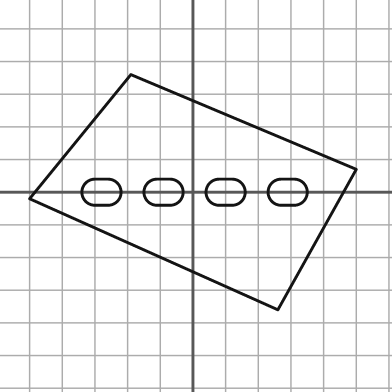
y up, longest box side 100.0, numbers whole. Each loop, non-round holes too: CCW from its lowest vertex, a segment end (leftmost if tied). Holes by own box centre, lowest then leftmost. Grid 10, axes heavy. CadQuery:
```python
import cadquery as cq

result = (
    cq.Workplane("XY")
    .moveTo(26.0, -36.0)
    .lineTo(50.0, 7.0)
    .lineTo(-19.0, 36.0)
    .lineTo(-50.0, -2.0)
    .close()
    .moveTo(-30.0, -4.0)
    .lineTo(-26.0, -4.0)
    .threePointArc((-22.0, 0.0), (-26.0, 4.0))
    .lineTo(-30.0, 4.0)
    .threePointArc((-34.0, 0.0), (-30.0, -4.0))
    .close()
    .moveTo(-11.0, -4.0)
    .lineTo(-7.0, -4.0)
    .threePointArc((-3.0, 0.0), (-7.0, 4.0))
    .lineTo(-11.0, 4.0)
    .threePointArc((-15.0, 0.0), (-11.0, -4.0))
    .close()
    .moveTo(8.0, -4.0)
    .lineTo(12.0, -4.0)
    .threePointArc((16.0, 0.0), (12.0, 4.0))
    .lineTo(8.0, 4.0)
    .threePointArc((4.0, 0.0), (8.0, -4.0))
    .close()
    .moveTo(27.0, -4.0)
    .lineTo(31.0, -4.0)
    .threePointArc((35.0, 0.0), (31.0, 4.0))
    .lineTo(27.0, 4.0)
    .threePointArc((23.0, 0.0), (27.0, -4.0))
    .close()
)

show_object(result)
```